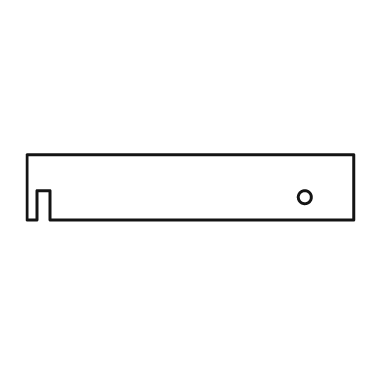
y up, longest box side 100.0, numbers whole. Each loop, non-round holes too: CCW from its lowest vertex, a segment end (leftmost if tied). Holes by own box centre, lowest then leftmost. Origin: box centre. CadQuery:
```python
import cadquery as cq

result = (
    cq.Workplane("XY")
    .moveTo(-50.0, -10.0)
    .lineTo(-47.0, -10.0)
    .lineTo(-47.0, -1.0)
    .lineTo(-43.0, -1.0)
    .lineTo(-43.0, -10.0)
    .lineTo(50.0, -10.0)
    .lineTo(50.0, 10.0)
    .lineTo(-50.0, 10.0)
    .close()
    .moveTo(35.0, -3.0)
    .circle(2.0)
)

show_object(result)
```